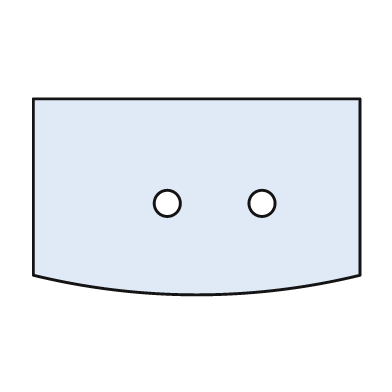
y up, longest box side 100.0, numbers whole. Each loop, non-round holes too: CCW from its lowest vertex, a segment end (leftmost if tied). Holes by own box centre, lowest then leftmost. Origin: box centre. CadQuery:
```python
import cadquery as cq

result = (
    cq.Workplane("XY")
    .moveTo(-50.0, -24.0)
    .threePointArc((0.0, -30.0), (50.0, -24.0))
    .lineTo(50.0, 30.0)
    .lineTo(-50.0, 30.0)
    .close()
    .moveTo(-9.0, -2.0)
    .circle(4.0)
    .moveTo(20.0, -2.0)
    .circle(4.0)
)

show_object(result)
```